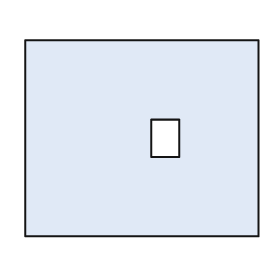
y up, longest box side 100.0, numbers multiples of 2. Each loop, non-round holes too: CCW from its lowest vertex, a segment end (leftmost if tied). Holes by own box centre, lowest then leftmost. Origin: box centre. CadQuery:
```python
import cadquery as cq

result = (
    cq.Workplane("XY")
    .moveTo(-50.0, -42.0)
    .lineTo(50.0, -42.0)
    .lineTo(50.0, 42.0)
    .lineTo(-50.0, 42.0)
    .close()
    .moveTo(4.0, -8.0)
    .lineTo(16.0, -8.0)
    .lineTo(16.0, 8.0)
    .lineTo(4.0, 8.0)
    .close()
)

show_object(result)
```